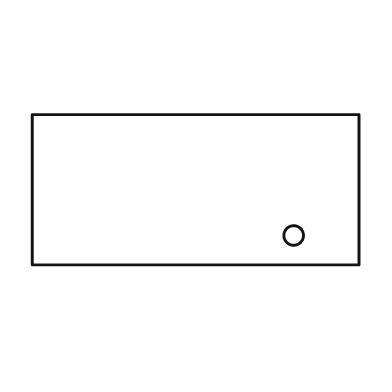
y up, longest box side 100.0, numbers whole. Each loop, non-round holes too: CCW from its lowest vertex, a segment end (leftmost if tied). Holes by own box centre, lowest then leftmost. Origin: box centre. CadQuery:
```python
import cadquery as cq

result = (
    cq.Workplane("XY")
    .moveTo(-50.0, -23.0)
    .lineTo(50.0, -23.0)
    .lineTo(50.0, 23.0)
    .lineTo(-50.0, 23.0)
    .close()
    .moveTo(30.0, -14.0)
    .circle(3.0)
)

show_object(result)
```